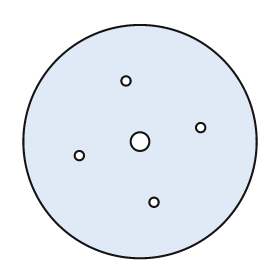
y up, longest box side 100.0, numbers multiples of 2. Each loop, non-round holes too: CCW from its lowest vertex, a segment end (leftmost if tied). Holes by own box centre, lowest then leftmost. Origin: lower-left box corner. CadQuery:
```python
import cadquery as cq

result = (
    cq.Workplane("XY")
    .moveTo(50.0, 50.0)
    .circle(50.0)
    .moveTo(56.0, 24.0)
    .circle(2.0)
    .moveTo(24.0, 44.0)
    .circle(2.0)
    .moveTo(50.0, 50.0)
    .circle(4.0)
    .moveTo(76.0, 56.0)
    .circle(2.0)
    .moveTo(44.0, 76.0)
    .circle(2.0)
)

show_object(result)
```